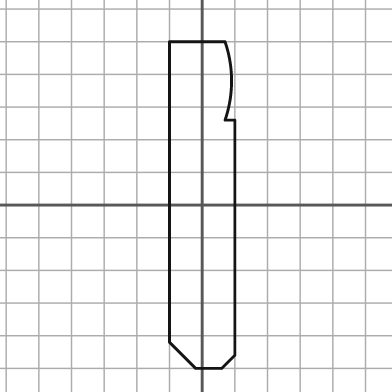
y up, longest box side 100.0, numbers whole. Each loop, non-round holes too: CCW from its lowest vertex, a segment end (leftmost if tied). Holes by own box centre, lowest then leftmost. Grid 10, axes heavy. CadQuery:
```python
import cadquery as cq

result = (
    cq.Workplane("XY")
    .moveTo(-2.0, -50.0)
    .lineTo(6.0, -50.0)
    .lineTo(10.0, -46.0)
    .lineTo(10.0, 26.0)
    .lineTo(7.0, 26.0)
    .threePointArc((9.0, 38.0), (7.0, 50.0))
    .lineTo(-10.0, 50.0)
    .lineTo(-10.0, -42.0)
    .close()
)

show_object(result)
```